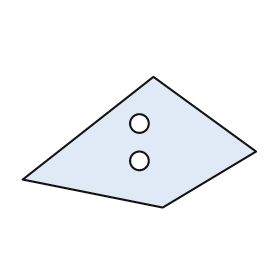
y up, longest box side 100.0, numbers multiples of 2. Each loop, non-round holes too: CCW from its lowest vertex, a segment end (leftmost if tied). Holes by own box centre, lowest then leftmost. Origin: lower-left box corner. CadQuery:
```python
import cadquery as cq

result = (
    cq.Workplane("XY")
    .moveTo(60.0, 0.0)
    .lineTo(100.0, 24.0)
    .lineTo(56.0, 56.0)
    .lineTo(0.0, 12.0)
    .close()
    .moveTo(50.0, 20.0)
    .circle(4.0)
    .moveTo(50.0, 36.0)
    .circle(4.0)
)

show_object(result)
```